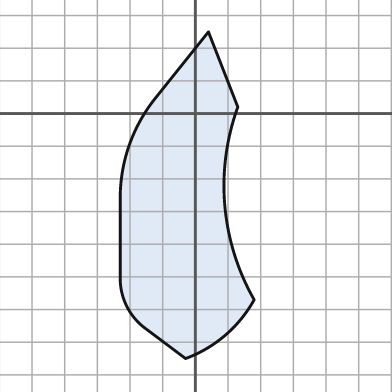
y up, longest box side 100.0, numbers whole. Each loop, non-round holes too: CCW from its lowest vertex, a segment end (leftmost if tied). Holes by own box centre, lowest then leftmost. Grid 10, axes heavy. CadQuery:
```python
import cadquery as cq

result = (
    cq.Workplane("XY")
    .moveTo(-3.0, -75.0)
    .threePointArc((9.0, -68.0), (18.0, -57.0))
    .threePointArc((9.0, -28.0), (13.0, 2.0))
    .lineTo(4.0, 25.0)
    .lineTo(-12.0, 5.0)
    .threePointArc((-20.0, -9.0), (-23.0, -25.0))
    .lineTo(-23.0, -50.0)
    .threePointArc((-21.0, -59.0), (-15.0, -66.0))
    .close()
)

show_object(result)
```